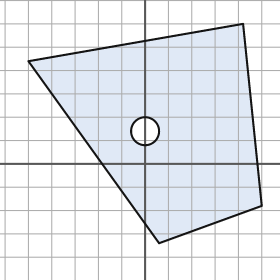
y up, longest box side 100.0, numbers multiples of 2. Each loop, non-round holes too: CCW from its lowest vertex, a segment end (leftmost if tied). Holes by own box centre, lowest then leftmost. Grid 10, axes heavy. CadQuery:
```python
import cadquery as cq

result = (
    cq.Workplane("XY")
    .moveTo(6.0, -34.0)
    .lineTo(50.0, -18.0)
    .lineTo(42.0, 60.0)
    .lineTo(-50.0, 44.0)
    .close()
    .moveTo(0.0, 14.0)
    .circle(6.0)
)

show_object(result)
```